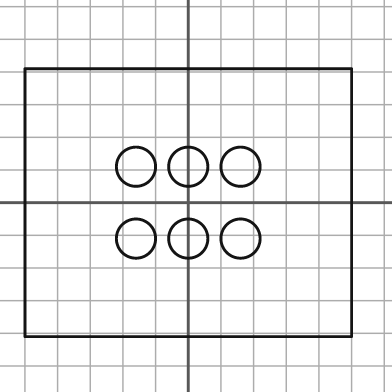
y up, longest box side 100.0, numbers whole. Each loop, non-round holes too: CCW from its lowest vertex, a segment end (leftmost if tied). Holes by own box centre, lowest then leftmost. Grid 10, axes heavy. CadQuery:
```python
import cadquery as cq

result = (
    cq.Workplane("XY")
    .moveTo(-50.0, -41.0)
    .lineTo(50.0, -41.0)
    .lineTo(50.0, 41.0)
    .lineTo(-50.0, 41.0)
    .close()
    .moveTo(-16.0, -11.0)
    .circle(6.0)
    .moveTo(0.0, -11.0)
    .circle(6.0)
    .moveTo(16.0, -11.0)
    .circle(6.0)
    .moveTo(-16.0, 11.0)
    .circle(6.0)
    .moveTo(0.0, 11.0)
    .circle(6.0)
    .moveTo(16.0, 11.0)
    .circle(6.0)
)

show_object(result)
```